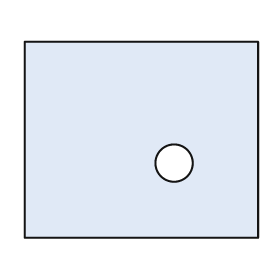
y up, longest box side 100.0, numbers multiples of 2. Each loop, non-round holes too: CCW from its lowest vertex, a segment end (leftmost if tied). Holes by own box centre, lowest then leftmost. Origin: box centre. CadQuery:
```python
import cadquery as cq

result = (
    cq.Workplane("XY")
    .moveTo(-50.0, -42.0)
    .lineTo(50.0, -42.0)
    .lineTo(50.0, 42.0)
    .lineTo(-50.0, 42.0)
    .close()
    .moveTo(14.0, -10.0)
    .circle(8.0)
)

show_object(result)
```